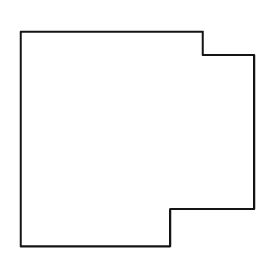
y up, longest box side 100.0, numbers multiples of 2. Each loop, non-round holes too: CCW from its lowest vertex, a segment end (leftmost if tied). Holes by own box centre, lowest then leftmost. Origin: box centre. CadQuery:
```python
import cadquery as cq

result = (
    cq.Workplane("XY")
    .moveTo(-50.0, -46.0)
    .lineTo(14.0, -46.0)
    .lineTo(14.0, -30.0)
    .lineTo(50.0, -30.0)
    .lineTo(50.0, 36.0)
    .lineTo(28.0, 36.0)
    .lineTo(28.0, 46.0)
    .lineTo(-50.0, 46.0)
    .close()
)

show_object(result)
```